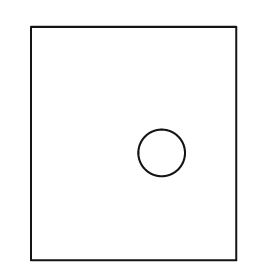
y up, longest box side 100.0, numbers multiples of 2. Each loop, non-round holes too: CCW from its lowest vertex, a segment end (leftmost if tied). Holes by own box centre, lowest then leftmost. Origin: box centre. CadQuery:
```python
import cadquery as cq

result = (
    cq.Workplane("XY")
    .moveTo(-44.0, -50.0)
    .lineTo(44.0, -50.0)
    .lineTo(44.0, 50.0)
    .lineTo(-44.0, 50.0)
    .close()
    .moveTo(12.0, -4.0)
    .circle(10.0)
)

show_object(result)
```